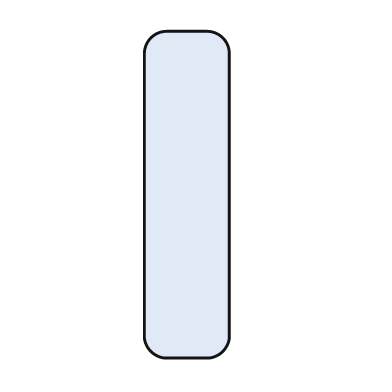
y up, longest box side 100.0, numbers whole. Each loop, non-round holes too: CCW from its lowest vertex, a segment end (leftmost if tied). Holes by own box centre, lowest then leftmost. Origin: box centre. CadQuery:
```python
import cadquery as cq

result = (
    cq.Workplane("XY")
    .moveTo(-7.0, -50.0)
    .lineTo(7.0, -50.0)
    .threePointArc((11.0, -48.0), (13.0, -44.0))
    .lineTo(13.0, 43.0)
    .threePointArc((11.0, 48.0), (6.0, 50.0))
    .lineTo(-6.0, 50.0)
    .threePointArc((-11.0, 48.0), (-13.0, 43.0))
    .lineTo(-13.0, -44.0)
    .threePointArc((-11.0, -48.0), (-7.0, -50.0))
    .close()
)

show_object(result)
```